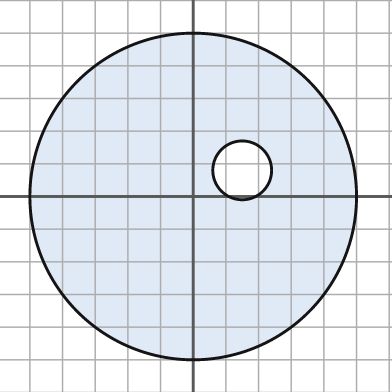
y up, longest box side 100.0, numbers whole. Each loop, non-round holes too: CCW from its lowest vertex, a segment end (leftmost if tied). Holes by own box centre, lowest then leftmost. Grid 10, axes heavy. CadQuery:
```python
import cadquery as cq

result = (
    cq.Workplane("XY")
    .moveTo(0.0, 0.0)
    .circle(50.0)
    .moveTo(15.0, 8.0)
    .circle(9.0)
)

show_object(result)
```